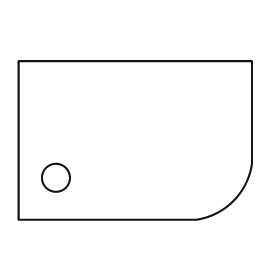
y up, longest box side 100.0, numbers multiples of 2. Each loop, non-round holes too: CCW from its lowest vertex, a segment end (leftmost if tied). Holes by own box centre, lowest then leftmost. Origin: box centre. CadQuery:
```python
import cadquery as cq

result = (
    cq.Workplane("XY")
    .moveTo(-50.0, -34.0)
    .lineTo(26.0, -34.0)
    .threePointArc((42.0, -26.0), (50.0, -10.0))
    .lineTo(50.0, 34.0)
    .lineTo(-50.0, 34.0)
    .close()
    .moveTo(-34.0, -16.0)
    .circle(6.0)
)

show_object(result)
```